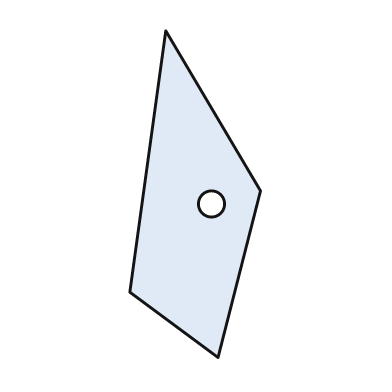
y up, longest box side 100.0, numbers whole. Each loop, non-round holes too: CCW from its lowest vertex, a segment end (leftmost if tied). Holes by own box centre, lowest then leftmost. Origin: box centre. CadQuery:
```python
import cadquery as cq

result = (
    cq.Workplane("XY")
    .moveTo(7.0, -50.0)
    .lineTo(20.0, 1.0)
    .lineTo(-9.0, 50.0)
    .lineTo(-20.0, -30.0)
    .close()
    .moveTo(5.0, -3.0)
    .circle(4.0)
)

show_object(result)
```